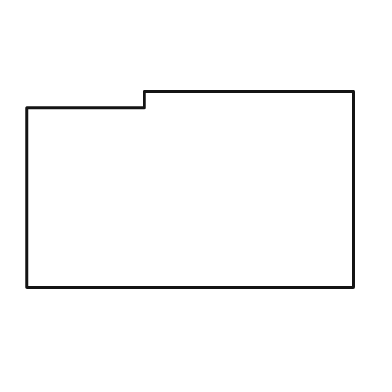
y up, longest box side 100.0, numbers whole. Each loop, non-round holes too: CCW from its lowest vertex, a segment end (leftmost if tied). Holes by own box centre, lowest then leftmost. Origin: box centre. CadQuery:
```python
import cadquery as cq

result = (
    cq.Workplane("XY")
    .moveTo(-50.0, -30.0)
    .lineTo(50.0, -30.0)
    .lineTo(50.0, 30.0)
    .lineTo(-14.0, 30.0)
    .lineTo(-14.0, 25.0)
    .lineTo(-50.0, 25.0)
    .close()
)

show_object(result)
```